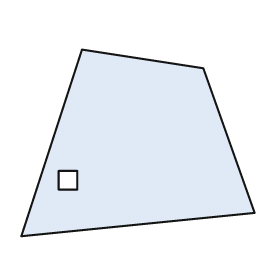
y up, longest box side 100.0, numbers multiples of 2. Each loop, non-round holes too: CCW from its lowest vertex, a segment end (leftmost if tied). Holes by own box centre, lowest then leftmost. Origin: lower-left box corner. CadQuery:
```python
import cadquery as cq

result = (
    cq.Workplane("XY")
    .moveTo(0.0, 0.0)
    .lineTo(100.0, 10.0)
    .lineTo(78.0, 72.0)
    .lineTo(26.0, 80.0)
    .close()
    .moveTo(16.0, 20.0)
    .lineTo(24.0, 20.0)
    .lineTo(24.0, 28.0)
    .lineTo(16.0, 28.0)
    .close()
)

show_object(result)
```